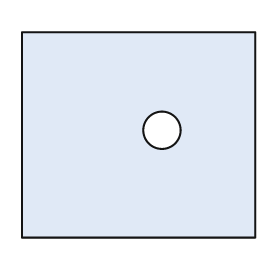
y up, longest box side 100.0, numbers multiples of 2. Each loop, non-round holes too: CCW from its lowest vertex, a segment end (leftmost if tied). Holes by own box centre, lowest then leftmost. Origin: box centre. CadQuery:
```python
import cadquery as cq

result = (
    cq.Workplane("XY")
    .moveTo(-50.0, -44.0)
    .lineTo(50.0, -44.0)
    .lineTo(50.0, 44.0)
    .lineTo(-50.0, 44.0)
    .close()
    .moveTo(10.0, 2.0)
    .circle(8.0)
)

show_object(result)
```